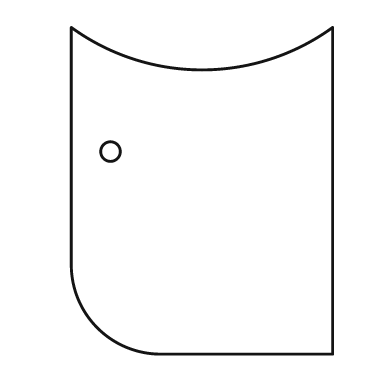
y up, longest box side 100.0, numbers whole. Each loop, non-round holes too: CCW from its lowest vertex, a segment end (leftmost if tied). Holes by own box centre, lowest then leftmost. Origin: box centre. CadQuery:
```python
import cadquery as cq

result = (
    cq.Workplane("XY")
    .moveTo(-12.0, -50.0)
    .lineTo(40.0, -50.0)
    .lineTo(40.0, 50.0)
    .threePointArc((0.0, 37.0), (-40.0, 50.0))
    .lineTo(-40.0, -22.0)
    .threePointArc((-32.0, -42.0), (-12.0, -50.0))
    .close()
    .moveTo(-28.0, 12.0)
    .circle(3.0)
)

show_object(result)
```